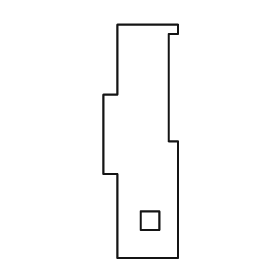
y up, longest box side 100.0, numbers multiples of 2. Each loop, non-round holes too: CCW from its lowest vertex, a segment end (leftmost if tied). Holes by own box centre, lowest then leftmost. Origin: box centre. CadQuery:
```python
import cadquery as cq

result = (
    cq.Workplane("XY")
    .moveTo(-10.0, -50.0)
    .lineTo(16.0, -50.0)
    .lineTo(16.0, 0.0)
    .lineTo(12.0, 0.0)
    .lineTo(12.0, 46.0)
    .lineTo(16.0, 46.0)
    .lineTo(16.0, 50.0)
    .lineTo(-10.0, 50.0)
    .lineTo(-10.0, 20.0)
    .lineTo(-16.0, 20.0)
    .lineTo(-16.0, -14.0)
    .lineTo(-10.0, -14.0)
    .close()
    .moveTo(0.0, -38.0)
    .lineTo(8.0, -38.0)
    .lineTo(8.0, -30.0)
    .lineTo(0.0, -30.0)
    .close()
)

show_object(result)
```